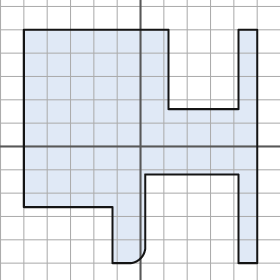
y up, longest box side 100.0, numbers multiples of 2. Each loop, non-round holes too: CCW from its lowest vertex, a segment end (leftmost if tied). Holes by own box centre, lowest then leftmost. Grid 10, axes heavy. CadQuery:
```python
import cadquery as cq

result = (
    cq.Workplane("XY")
    .moveTo(-12.0, -50.0)
    .lineTo(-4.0, -50.0)
    .threePointArc((0.0, -48.0), (2.0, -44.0))
    .lineTo(2.0, -12.0)
    .lineTo(42.0, -12.0)
    .lineTo(42.0, -50.0)
    .lineTo(50.0, -50.0)
    .lineTo(50.0, 50.0)
    .lineTo(42.0, 50.0)
    .lineTo(42.0, 16.0)
    .lineTo(12.0, 16.0)
    .lineTo(12.0, 50.0)
    .lineTo(-50.0, 50.0)
    .lineTo(-50.0, -26.0)
    .lineTo(-12.0, -26.0)
    .close()
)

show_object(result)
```